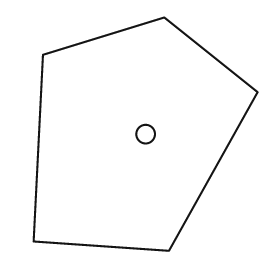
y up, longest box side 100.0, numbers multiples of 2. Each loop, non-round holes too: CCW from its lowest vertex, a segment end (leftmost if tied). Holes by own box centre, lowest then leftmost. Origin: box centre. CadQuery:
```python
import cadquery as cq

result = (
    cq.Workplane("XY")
    .moveTo(10.0, -50.0)
    .lineTo(48.0, 18.0)
    .lineTo(8.0, 50.0)
    .lineTo(-44.0, 34.0)
    .lineTo(-48.0, -46.0)
    .close()
    .moveTo(0.0, 0.0)
    .circle(4.0)
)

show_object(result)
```